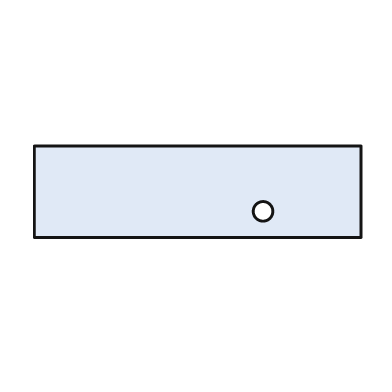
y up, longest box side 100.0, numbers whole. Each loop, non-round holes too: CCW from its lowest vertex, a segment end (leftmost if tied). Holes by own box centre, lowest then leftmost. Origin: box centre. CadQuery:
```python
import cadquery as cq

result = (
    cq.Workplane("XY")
    .moveTo(-50.0, -14.0)
    .lineTo(50.0, -14.0)
    .lineTo(50.0, 14.0)
    .lineTo(-50.0, 14.0)
    .close()
    .moveTo(20.0, -6.0)
    .circle(3.0)
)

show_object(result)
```